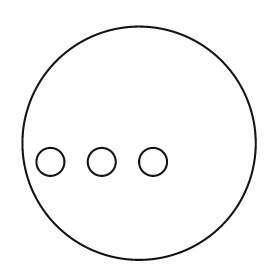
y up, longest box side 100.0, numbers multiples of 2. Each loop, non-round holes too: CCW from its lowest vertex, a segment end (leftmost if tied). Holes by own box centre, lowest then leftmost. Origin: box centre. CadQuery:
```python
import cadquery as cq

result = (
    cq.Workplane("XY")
    .moveTo(0.0, 0.0)
    .circle(50.0)
    .moveTo(-38.0, -8.0)
    .circle(6.0)
    .moveTo(-16.0, -8.0)
    .circle(6.0)
    .moveTo(6.0, -8.0)
    .circle(6.0)
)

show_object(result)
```